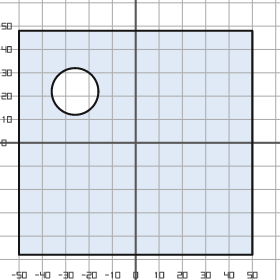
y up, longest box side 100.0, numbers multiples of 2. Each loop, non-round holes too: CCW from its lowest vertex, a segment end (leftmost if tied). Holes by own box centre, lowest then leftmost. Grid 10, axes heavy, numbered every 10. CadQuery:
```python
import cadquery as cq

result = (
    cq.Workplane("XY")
    .moveTo(-50.0, -48.0)
    .lineTo(50.0, -48.0)
    .lineTo(50.0, 48.0)
    .lineTo(-50.0, 48.0)
    .close()
    .moveTo(-26.0, 22.0)
    .circle(10.0)
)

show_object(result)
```